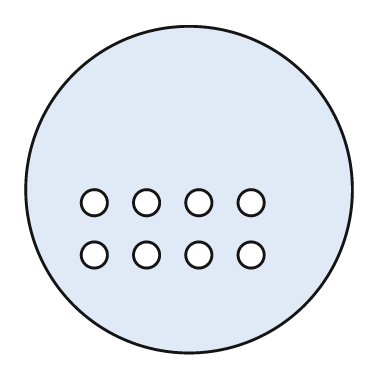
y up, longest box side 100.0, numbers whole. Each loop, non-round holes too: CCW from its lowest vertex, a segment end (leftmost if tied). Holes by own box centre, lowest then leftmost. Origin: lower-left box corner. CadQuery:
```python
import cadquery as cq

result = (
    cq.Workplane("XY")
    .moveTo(50.0, 50.0)
    .circle(50.0)
    .moveTo(21.0, 30.0)
    .circle(4.0)
    .moveTo(37.0, 30.0)
    .circle(4.0)
    .moveTo(53.0, 30.0)
    .circle(4.0)
    .moveTo(69.0, 30.0)
    .circle(4.0)
    .moveTo(21.0, 46.0)
    .circle(4.0)
    .moveTo(37.0, 46.0)
    .circle(4.0)
    .moveTo(53.0, 46.0)
    .circle(4.0)
    .moveTo(69.0, 46.0)
    .circle(4.0)
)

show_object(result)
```